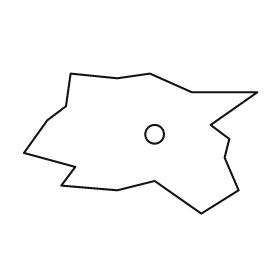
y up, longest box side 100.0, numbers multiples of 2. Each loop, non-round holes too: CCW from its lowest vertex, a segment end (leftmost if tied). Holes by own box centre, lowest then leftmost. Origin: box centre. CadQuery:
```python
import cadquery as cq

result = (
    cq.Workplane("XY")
    .moveTo(26.0, -30.0)
    .lineTo(42.0, -20.0)
    .lineTo(36.0, -6.0)
    .lineTo(38.0, 2.0)
    .lineTo(30.0, 8.0)
    .lineTo(50.0, 22.0)
    .lineTo(22.0, 22.0)
    .lineTo(4.0, 30.0)
    .lineTo(-10.0, 28.0)
    .lineTo(-30.0, 30.0)
    .lineTo(-32.0, 16.0)
    .lineTo(-40.0, 10.0)
    .lineTo(-50.0, -4.0)
    .lineTo(-28.0, -10.0)
    .lineTo(-34.0, -18.0)
    .lineTo(-10.0, -20.0)
    .lineTo(6.0, -16.0)
    .close()
    .moveTo(6.0, 4.0)
    .circle(4.0)
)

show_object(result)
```